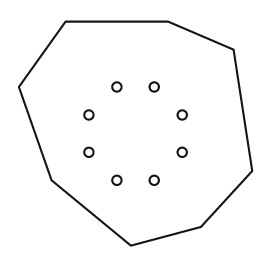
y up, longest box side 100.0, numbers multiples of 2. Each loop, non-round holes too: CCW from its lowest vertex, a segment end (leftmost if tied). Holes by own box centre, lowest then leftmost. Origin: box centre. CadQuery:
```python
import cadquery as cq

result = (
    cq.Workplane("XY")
    .moveTo(-2.0, -48.0)
    .lineTo(28.0, -40.0)
    .lineTo(50.0, -16.0)
    .lineTo(42.0, 36.0)
    .lineTo(14.0, 48.0)
    .lineTo(-30.0, 48.0)
    .lineTo(-50.0, 20.0)
    .lineTo(-36.0, -20.0)
    .close()
    .moveTo(-8.0, -20.0)
    .circle(2.0)
    .moveTo(8.0, -20.0)
    .circle(2.0)
    .moveTo(-20.0, -8.0)
    .circle(2.0)
    .moveTo(20.0, -8.0)
    .circle(2.0)
    .moveTo(-20.0, 8.0)
    .circle(2.0)
    .moveTo(20.0, 8.0)
    .circle(2.0)
    .moveTo(-8.0, 20.0)
    .circle(2.0)
    .moveTo(8.0, 20.0)
    .circle(2.0)
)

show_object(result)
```